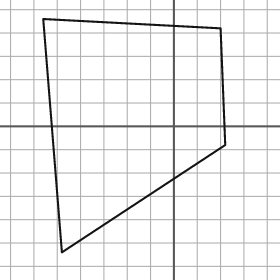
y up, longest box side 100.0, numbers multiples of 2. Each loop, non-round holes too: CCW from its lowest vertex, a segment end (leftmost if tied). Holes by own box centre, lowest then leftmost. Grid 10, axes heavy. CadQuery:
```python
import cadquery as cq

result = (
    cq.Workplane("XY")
    .moveTo(-48.0, -54.0)
    .lineTo(22.0, -8.0)
    .lineTo(20.0, 42.0)
    .lineTo(-56.0, 46.0)
    .close()
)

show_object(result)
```